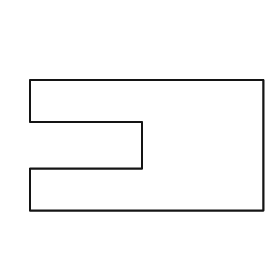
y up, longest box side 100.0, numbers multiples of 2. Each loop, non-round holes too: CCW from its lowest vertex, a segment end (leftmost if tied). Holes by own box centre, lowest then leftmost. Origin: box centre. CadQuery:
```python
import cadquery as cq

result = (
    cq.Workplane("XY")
    .moveTo(-50.0, -28.0)
    .lineTo(50.0, -28.0)
    .lineTo(50.0, 28.0)
    .lineTo(-50.0, 28.0)
    .lineTo(-50.0, 10.0)
    .lineTo(-2.0, 10.0)
    .lineTo(-2.0, -10.0)
    .lineTo(-50.0, -10.0)
    .close()
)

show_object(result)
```